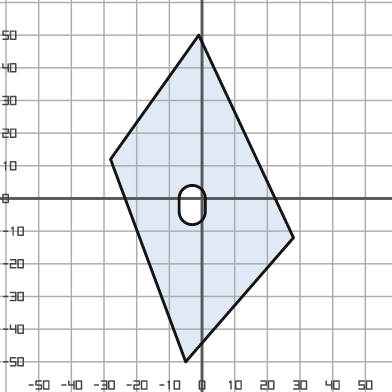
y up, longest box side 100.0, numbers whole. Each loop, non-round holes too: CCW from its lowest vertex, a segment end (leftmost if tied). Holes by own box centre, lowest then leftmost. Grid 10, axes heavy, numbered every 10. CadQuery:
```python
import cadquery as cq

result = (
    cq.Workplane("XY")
    .moveTo(-5.0, -50.0)
    .lineTo(28.0, -12.0)
    .lineTo(-1.0, 50.0)
    .lineTo(-28.0, 12.0)
    .close()
    .moveTo(-7.0, -4.0)
    .threePointArc((-3.0, -8.0), (1.0, -4.0))
    .lineTo(1.0, 0.0)
    .threePointArc((-3.0, 4.0), (-7.0, 0.0))
    .close()
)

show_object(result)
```